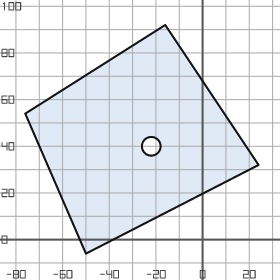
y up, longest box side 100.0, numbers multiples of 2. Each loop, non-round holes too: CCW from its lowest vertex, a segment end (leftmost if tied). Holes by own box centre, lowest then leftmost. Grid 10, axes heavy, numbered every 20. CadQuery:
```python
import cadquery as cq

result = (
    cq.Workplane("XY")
    .moveTo(-50.0, -6.0)
    .lineTo(24.0, 32.0)
    .lineTo(-16.0, 92.0)
    .lineTo(-76.0, 54.0)
    .close()
    .moveTo(-22.0, 40.0)
    .circle(4.0)
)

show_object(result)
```